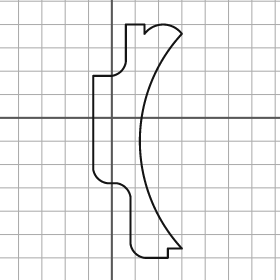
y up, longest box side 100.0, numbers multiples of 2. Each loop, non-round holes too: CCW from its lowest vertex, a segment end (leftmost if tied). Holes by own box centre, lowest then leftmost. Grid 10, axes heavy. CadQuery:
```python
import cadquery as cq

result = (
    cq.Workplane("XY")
    .moveTo(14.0, -60.0)
    .lineTo(24.0, -60.0)
    .lineTo(24.0, -56.0)
    .lineTo(30.0, -56.0)
    .threePointArc((12.0, -10.0), (30.0, 36.0))
    .threePointArc((22.0, 40.0), (14.0, 36.0))
    .lineTo(14.0, 40.0)
    .lineTo(6.0, 40.0)
    .lineTo(6.0, 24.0)
    .threePointArc((4.0, 20.0), (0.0, 18.0))
    .lineTo(-8.0, 18.0)
    .lineTo(-8.0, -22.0)
    .threePointArc((-6.0, -26.0), (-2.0, -28.0))
    .lineTo(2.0, -28.0)
    .threePointArc((6.0, -30.0), (8.0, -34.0))
    .lineTo(8.0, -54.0)
    .threePointArc((10.0, -58.0), (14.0, -60.0))
    .close()
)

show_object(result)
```